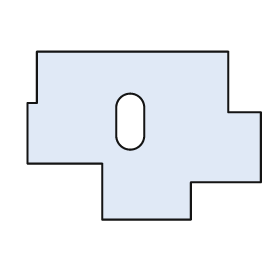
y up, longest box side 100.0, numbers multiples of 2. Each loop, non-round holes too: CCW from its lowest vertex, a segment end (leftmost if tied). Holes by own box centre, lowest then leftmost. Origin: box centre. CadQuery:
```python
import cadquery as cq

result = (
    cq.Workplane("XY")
    .moveTo(-18.0, -36.0)
    .lineTo(20.0, -36.0)
    .lineTo(20.0, -20.0)
    .lineTo(50.0, -20.0)
    .lineTo(50.0, 10.0)
    .lineTo(36.0, 10.0)
    .lineTo(36.0, 36.0)
    .lineTo(-46.0, 36.0)
    .lineTo(-46.0, 14.0)
    .lineTo(-50.0, 14.0)
    .lineTo(-50.0, -12.0)
    .lineTo(-18.0, -12.0)
    .close()
    .moveTo(-12.0, 0.0)
    .threePointArc((-6.0, -6.0), (0.0, 0.0))
    .lineTo(0.0, 12.0)
    .threePointArc((-6.0, 18.0), (-12.0, 12.0))
    .close()
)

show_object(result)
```